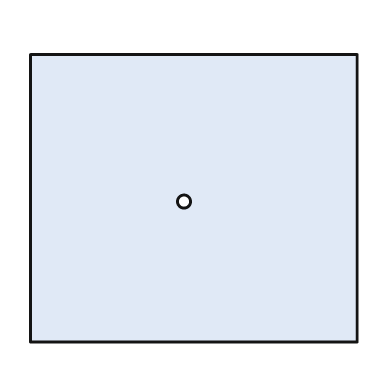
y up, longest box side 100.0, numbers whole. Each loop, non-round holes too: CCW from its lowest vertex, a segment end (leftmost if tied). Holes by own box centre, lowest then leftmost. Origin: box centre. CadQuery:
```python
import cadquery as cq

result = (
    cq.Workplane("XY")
    .moveTo(-50.0, -44.0)
    .lineTo(50.0, -44.0)
    .lineTo(50.0, 44.0)
    .lineTo(-50.0, 44.0)
    .close()
    .moveTo(-3.0, -1.0)
    .circle(2.0)
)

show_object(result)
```